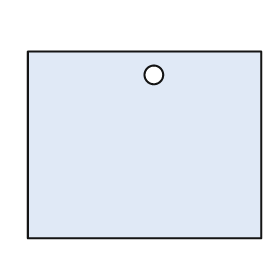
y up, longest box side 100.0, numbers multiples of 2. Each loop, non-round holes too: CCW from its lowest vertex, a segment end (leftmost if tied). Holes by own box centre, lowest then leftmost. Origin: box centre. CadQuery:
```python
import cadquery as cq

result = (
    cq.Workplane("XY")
    .moveTo(-50.0, -40.0)
    .lineTo(50.0, -40.0)
    .lineTo(50.0, 40.0)
    .lineTo(-50.0, 40.0)
    .close()
    .moveTo(4.0, 30.0)
    .circle(4.0)
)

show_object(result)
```